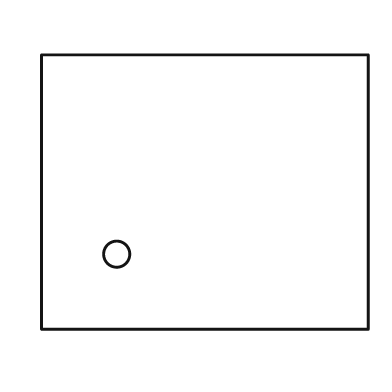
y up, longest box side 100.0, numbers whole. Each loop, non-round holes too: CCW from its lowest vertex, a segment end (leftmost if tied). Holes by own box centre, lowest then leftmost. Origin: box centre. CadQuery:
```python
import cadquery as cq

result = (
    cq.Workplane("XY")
    .moveTo(-50.0, -42.0)
    .lineTo(50.0, -42.0)
    .lineTo(50.0, 42.0)
    .lineTo(-50.0, 42.0)
    .close()
    .moveTo(-27.0, -19.0)
    .circle(4.0)
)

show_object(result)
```